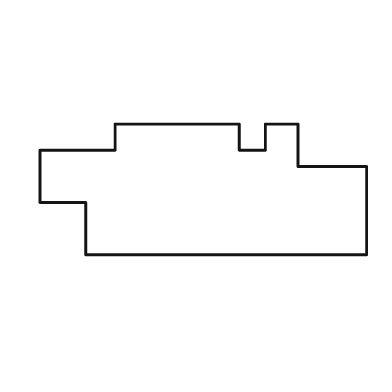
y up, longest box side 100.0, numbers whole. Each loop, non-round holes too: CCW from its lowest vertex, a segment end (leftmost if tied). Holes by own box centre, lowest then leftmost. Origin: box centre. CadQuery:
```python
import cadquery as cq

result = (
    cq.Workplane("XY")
    .moveTo(-36.0, -20.0)
    .lineTo(50.0, -20.0)
    .lineTo(50.0, 7.0)
    .lineTo(29.0, 7.0)
    .lineTo(29.0, 20.0)
    .lineTo(19.0, 20.0)
    .lineTo(19.0, 12.0)
    .lineTo(11.0, 12.0)
    .lineTo(11.0, 20.0)
    .lineTo(-27.0, 20.0)
    .lineTo(-27.0, 12.0)
    .lineTo(-50.0, 12.0)
    .lineTo(-50.0, -4.0)
    .lineTo(-36.0, -4.0)
    .close()
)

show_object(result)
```